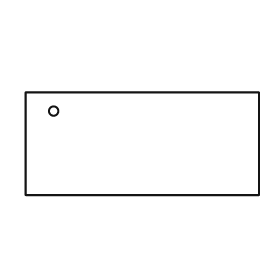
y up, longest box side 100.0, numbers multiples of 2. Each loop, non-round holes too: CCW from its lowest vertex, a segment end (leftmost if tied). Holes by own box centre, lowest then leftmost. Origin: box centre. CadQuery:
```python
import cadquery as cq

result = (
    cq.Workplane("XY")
    .moveTo(-50.0, -22.0)
    .lineTo(50.0, -22.0)
    .lineTo(50.0, 22.0)
    .lineTo(-50.0, 22.0)
    .close()
    .moveTo(-38.0, 14.0)
    .circle(2.0)
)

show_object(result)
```